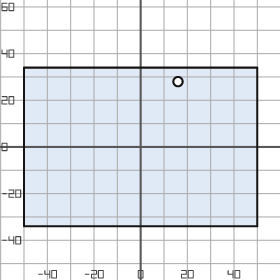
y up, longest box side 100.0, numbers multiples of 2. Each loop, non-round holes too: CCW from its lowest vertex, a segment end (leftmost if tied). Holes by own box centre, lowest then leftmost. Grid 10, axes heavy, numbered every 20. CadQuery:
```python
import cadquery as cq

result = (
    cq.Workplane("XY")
    .moveTo(-50.0, -34.0)
    .lineTo(50.0, -34.0)
    .lineTo(50.0, 34.0)
    .lineTo(-50.0, 34.0)
    .close()
    .moveTo(16.0, 28.0)
    .circle(2.0)
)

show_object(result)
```